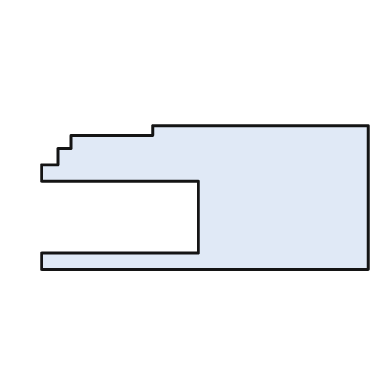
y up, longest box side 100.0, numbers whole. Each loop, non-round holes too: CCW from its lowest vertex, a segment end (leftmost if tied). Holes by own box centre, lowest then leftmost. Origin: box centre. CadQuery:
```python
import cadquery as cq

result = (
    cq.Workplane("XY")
    .moveTo(-50.0, -22.0)
    .lineTo(50.0, -22.0)
    .lineTo(50.0, 22.0)
    .lineTo(-16.0, 22.0)
    .lineTo(-16.0, 19.0)
    .lineTo(-41.0, 19.0)
    .lineTo(-41.0, 15.0)
    .lineTo(-45.0, 15.0)
    .lineTo(-45.0, 10.0)
    .lineTo(-50.0, 10.0)
    .lineTo(-50.0, 5.0)
    .lineTo(-2.0, 5.0)
    .lineTo(-2.0, -17.0)
    .lineTo(-50.0, -17.0)
    .close()
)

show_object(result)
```